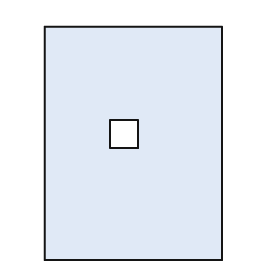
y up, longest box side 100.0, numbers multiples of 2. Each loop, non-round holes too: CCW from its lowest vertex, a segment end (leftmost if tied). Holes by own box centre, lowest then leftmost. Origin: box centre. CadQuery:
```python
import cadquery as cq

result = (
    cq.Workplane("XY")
    .moveTo(-38.0, -50.0)
    .lineTo(38.0, -50.0)
    .lineTo(38.0, 50.0)
    .lineTo(-38.0, 50.0)
    .close()
    .moveTo(-10.0, -2.0)
    .lineTo(2.0, -2.0)
    .lineTo(2.0, 10.0)
    .lineTo(-10.0, 10.0)
    .close()
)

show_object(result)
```